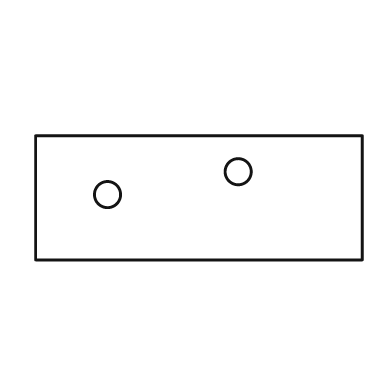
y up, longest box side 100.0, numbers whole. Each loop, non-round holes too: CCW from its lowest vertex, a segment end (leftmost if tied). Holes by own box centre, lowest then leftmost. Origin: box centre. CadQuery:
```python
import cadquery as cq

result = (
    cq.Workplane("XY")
    .moveTo(-50.0, -19.0)
    .lineTo(50.0, -19.0)
    .lineTo(50.0, 19.0)
    .lineTo(-50.0, 19.0)
    .close()
    .moveTo(-28.0, 1.0)
    .circle(4.0)
    .moveTo(12.0, 8.0)
    .circle(4.0)
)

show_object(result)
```